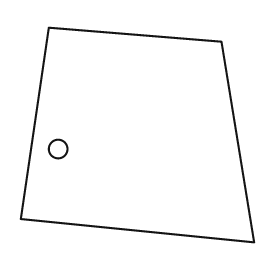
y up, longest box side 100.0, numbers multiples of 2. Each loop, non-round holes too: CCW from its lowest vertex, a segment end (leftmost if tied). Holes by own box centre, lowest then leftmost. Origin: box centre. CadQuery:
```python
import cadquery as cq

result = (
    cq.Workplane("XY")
    .moveTo(50.0, -46.0)
    .lineTo(36.0, 40.0)
    .lineTo(-38.0, 46.0)
    .lineTo(-50.0, -36.0)
    .close()
    .moveTo(-34.0, -6.0)
    .circle(4.0)
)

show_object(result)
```